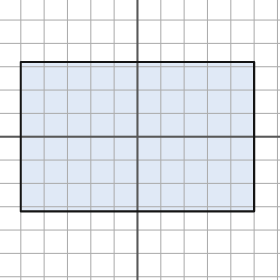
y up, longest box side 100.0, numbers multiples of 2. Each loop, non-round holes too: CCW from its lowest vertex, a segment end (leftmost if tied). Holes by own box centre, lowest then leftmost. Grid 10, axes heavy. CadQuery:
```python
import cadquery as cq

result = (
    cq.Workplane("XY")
    .moveTo(-50.0, -32.0)
    .lineTo(50.0, -32.0)
    .lineTo(50.0, 32.0)
    .lineTo(-50.0, 32.0)
    .close()
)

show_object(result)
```